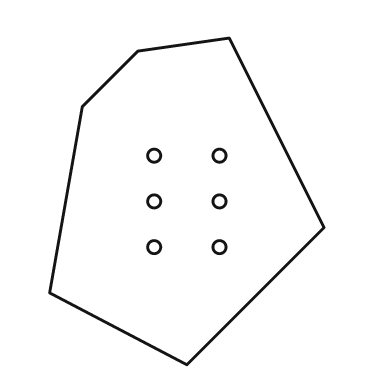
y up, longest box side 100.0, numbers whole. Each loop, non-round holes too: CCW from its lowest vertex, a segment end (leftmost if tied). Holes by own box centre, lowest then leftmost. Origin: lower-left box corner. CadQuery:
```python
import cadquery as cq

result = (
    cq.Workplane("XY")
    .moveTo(42.0, 0.0)
    .lineTo(84.0, 42.0)
    .lineTo(55.0, 100.0)
    .lineTo(27.0, 96.0)
    .lineTo(10.0, 79.0)
    .lineTo(0.0, 22.0)
    .close()
    .moveTo(32.0, 36.0)
    .circle(2.0)
    .moveTo(52.0, 36.0)
    .circle(2.0)
    .moveTo(32.0, 50.0)
    .circle(2.0)
    .moveTo(52.0, 50.0)
    .circle(2.0)
    .moveTo(32.0, 64.0)
    .circle(2.0)
    .moveTo(52.0, 64.0)
    .circle(2.0)
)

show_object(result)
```